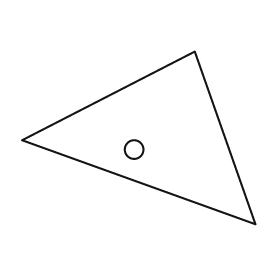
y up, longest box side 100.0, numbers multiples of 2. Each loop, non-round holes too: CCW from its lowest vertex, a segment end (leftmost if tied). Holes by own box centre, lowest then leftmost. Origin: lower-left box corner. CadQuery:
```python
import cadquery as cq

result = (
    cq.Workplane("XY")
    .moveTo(100.0, 0.0)
    .lineTo(74.0, 74.0)
    .lineTo(0.0, 36.0)
    .close()
    .moveTo(48.0, 32.0)
    .circle(4.0)
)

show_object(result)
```